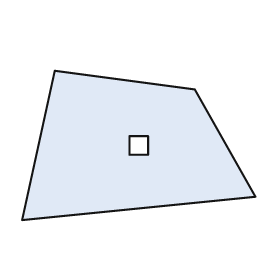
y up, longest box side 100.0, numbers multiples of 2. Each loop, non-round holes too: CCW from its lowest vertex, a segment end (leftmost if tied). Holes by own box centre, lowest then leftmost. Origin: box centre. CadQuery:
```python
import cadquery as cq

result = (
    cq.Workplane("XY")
    .moveTo(-50.0, -32.0)
    .lineTo(50.0, -22.0)
    .lineTo(24.0, 24.0)
    .lineTo(-36.0, 32.0)
    .close()
    .moveTo(-4.0, -4.0)
    .lineTo(4.0, -4.0)
    .lineTo(4.0, 4.0)
    .lineTo(-4.0, 4.0)
    .close()
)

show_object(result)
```